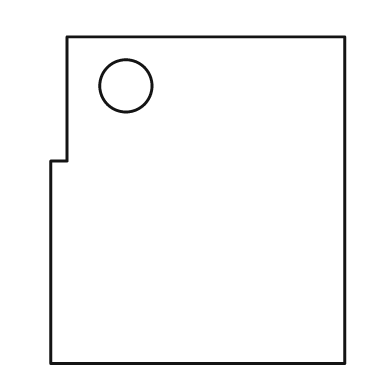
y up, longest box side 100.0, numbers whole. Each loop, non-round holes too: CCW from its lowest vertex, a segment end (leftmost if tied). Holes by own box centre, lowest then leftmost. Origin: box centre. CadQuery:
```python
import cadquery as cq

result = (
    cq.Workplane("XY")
    .moveTo(-45.0, -50.0)
    .lineTo(45.0, -50.0)
    .lineTo(45.0, 50.0)
    .lineTo(-40.0, 50.0)
    .lineTo(-40.0, 12.0)
    .lineTo(-45.0, 12.0)
    .close()
    .moveTo(-22.0, 35.0)
    .circle(8.0)
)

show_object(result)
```